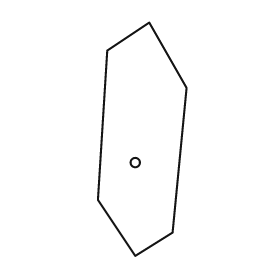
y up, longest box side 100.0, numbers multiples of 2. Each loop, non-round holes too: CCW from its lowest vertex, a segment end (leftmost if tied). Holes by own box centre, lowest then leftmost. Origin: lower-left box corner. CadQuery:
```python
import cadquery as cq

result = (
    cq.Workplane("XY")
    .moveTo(16.0, 0.0)
    .lineTo(32.0, 10.0)
    .lineTo(38.0, 72.0)
    .lineTo(22.0, 100.0)
    .lineTo(4.0, 88.0)
    .lineTo(0.0, 24.0)
    .close()
    .moveTo(16.0, 40.0)
    .circle(2.0)
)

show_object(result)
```